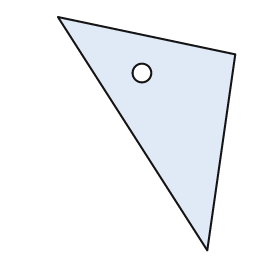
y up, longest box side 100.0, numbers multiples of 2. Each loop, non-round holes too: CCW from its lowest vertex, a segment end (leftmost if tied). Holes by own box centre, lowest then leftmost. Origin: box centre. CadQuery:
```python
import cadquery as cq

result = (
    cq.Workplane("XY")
    .moveTo(26.0, -50.0)
    .lineTo(38.0, 34.0)
    .lineTo(-38.0, 50.0)
    .close()
    .moveTo(-2.0, 26.0)
    .circle(4.0)
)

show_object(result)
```